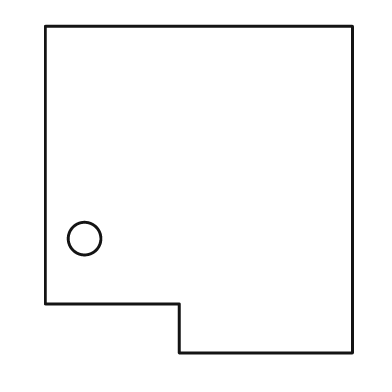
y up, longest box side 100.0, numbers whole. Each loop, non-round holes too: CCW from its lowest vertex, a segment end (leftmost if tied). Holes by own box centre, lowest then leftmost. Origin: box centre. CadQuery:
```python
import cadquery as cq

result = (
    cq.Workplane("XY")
    .moveTo(-6.0, -50.0)
    .lineTo(47.0, -50.0)
    .lineTo(47.0, 50.0)
    .lineTo(-47.0, 50.0)
    .lineTo(-47.0, -35.0)
    .lineTo(-6.0, -35.0)
    .close()
    .moveTo(-35.0, -15.0)
    .circle(5.0)
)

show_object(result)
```